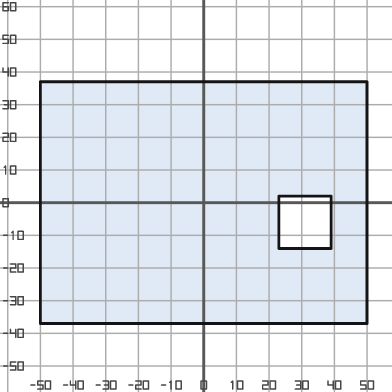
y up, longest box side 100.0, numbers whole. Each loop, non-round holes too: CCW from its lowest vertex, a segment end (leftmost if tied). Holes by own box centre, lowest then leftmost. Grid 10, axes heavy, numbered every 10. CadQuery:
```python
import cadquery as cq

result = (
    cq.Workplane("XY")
    .moveTo(-50.0, -37.0)
    .lineTo(50.0, -37.0)
    .lineTo(50.0, 37.0)
    .lineTo(-50.0, 37.0)
    .close()
    .moveTo(23.0, -14.0)
    .lineTo(39.0, -14.0)
    .lineTo(39.0, 2.0)
    .lineTo(23.0, 2.0)
    .close()
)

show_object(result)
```